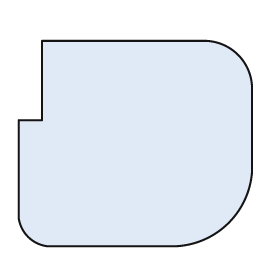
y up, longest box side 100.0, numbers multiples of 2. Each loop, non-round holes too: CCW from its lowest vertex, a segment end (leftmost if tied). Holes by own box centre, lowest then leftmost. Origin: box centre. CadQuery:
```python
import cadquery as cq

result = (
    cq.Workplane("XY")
    .moveTo(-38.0, -44.0)
    .lineTo(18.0, -44.0)
    .threePointArc((40.0, -34.0), (50.0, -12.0))
    .lineTo(50.0, 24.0)
    .threePointArc((44.0, 38.0), (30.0, 44.0))
    .lineTo(-40.0, 44.0)
    .lineTo(-40.0, 10.0)
    .lineTo(-50.0, 10.0)
    .lineTo(-50.0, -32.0)
    .threePointArc((-46.0, -40.0), (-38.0, -44.0))
    .close()
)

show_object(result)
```